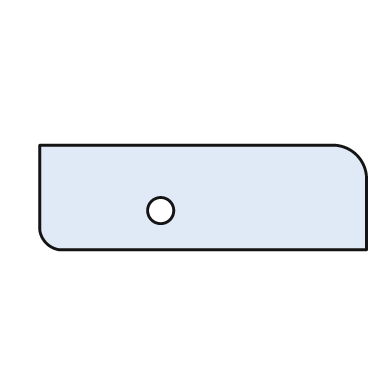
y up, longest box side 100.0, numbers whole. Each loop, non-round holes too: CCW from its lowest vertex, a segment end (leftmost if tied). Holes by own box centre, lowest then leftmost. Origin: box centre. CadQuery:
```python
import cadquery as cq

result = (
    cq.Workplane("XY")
    .moveTo(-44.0, -16.0)
    .lineTo(50.0, -16.0)
    .lineTo(50.0, 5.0)
    .threePointArc((47.0, 13.0), (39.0, 16.0))
    .lineTo(-50.0, 16.0)
    .lineTo(-50.0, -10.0)
    .threePointArc((-48.0, -14.0), (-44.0, -16.0))
    .close()
    .moveTo(-13.0, -4.0)
    .circle(4.0)
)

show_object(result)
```